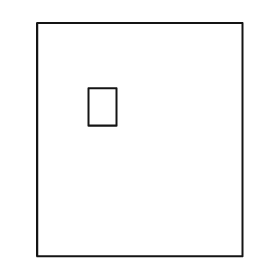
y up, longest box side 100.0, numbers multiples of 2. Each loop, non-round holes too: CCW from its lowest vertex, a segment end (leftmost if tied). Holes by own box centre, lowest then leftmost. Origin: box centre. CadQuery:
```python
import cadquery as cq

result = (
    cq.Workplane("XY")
    .moveTo(-44.0, -50.0)
    .lineTo(44.0, -50.0)
    .lineTo(44.0, 50.0)
    .lineTo(-44.0, 50.0)
    .close()
    .moveTo(-22.0, 6.0)
    .lineTo(-10.0, 6.0)
    .lineTo(-10.0, 22.0)
    .lineTo(-22.0, 22.0)
    .close()
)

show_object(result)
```